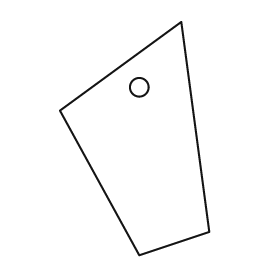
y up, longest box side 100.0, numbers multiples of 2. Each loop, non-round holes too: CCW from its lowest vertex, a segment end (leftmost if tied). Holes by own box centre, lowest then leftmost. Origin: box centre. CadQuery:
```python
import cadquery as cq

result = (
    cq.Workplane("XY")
    .moveTo(2.0, -50.0)
    .lineTo(32.0, -40.0)
    .lineTo(20.0, 50.0)
    .lineTo(-32.0, 12.0)
    .close()
    .moveTo(2.0, 22.0)
    .circle(4.0)
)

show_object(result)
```